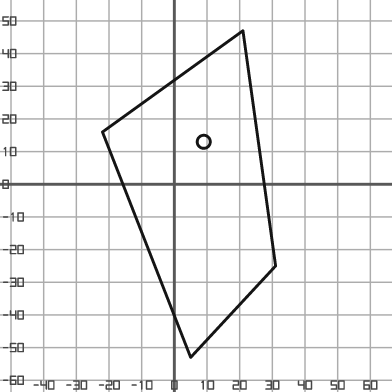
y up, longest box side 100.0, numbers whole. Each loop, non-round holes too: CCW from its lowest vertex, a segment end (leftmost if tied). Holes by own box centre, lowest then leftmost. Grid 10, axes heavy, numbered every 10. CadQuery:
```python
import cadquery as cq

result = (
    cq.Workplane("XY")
    .moveTo(5.0, -53.0)
    .lineTo(31.0, -25.0)
    .lineTo(21.0, 47.0)
    .lineTo(-22.0, 16.0)
    .close()
    .moveTo(9.0, 13.0)
    .circle(2.0)
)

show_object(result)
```